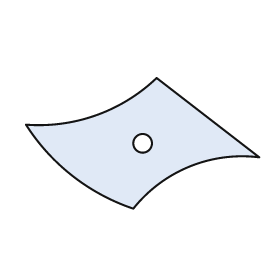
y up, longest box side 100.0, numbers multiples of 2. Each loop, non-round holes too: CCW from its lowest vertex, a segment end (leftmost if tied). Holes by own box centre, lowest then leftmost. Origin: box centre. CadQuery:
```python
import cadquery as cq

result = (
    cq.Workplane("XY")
    .moveTo(-4.0, -28.0)
    .threePointArc((20.0, -10.0), (50.0, -6.0))
    .lineTo(6.0, 28.0)
    .threePointArc((-20.0, 12.0), (-50.0, 8.0))
    .threePointArc((-30.0, -14.0), (-4.0, -28.0))
    .close()
    .moveTo(0.0, 0.0)
    .circle(4.0)
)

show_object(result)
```